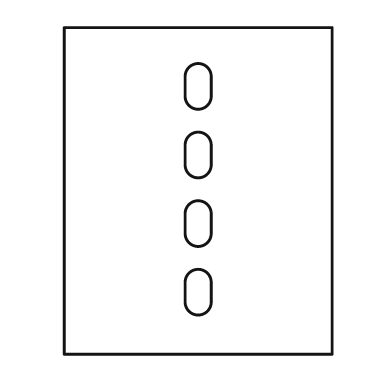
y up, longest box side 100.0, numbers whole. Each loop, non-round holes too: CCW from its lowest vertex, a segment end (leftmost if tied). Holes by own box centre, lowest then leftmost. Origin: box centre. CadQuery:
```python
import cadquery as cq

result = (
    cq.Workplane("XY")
    .moveTo(-41.0, -50.0)
    .lineTo(41.0, -50.0)
    .lineTo(41.0, 50.0)
    .lineTo(-41.0, 50.0)
    .close()
    .moveTo(-4.0, -34.0)
    .threePointArc((0.0, -38.0), (4.0, -34.0))
    .lineTo(4.0, -28.0)
    .threePointArc((0.0, -24.0), (-4.0, -28.0))
    .close()
    .moveTo(-4.0, -13.0)
    .threePointArc((0.0, -17.0), (4.0, -13.0))
    .lineTo(4.0, -7.0)
    .threePointArc((0.0, -3.0), (-4.0, -7.0))
    .close()
    .moveTo(-4.0, 8.0)
    .threePointArc((0.0, 4.0), (4.0, 8.0))
    .lineTo(4.0, 14.0)
    .threePointArc((0.0, 18.0), (-4.0, 14.0))
    .close()
    .moveTo(-4.0, 29.0)
    .threePointArc((0.0, 25.0), (4.0, 29.0))
    .lineTo(4.0, 35.0)
    .threePointArc((0.0, 39.0), (-4.0, 35.0))
    .close()
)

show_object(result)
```